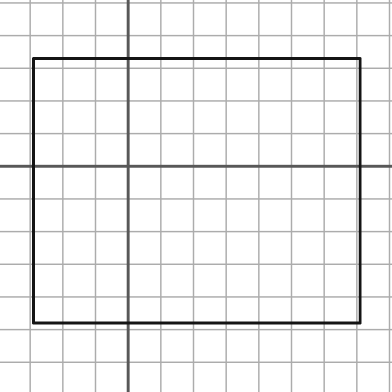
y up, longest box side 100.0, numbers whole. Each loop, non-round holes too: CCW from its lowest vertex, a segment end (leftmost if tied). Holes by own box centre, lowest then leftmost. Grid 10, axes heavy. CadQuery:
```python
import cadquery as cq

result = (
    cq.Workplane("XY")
    .moveTo(-29.0, -48.0)
    .lineTo(71.0, -48.0)
    .lineTo(71.0, 33.0)
    .lineTo(-29.0, 33.0)
    .close()
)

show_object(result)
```